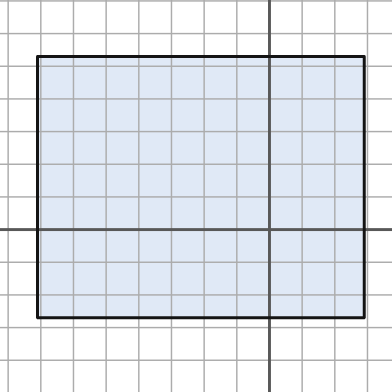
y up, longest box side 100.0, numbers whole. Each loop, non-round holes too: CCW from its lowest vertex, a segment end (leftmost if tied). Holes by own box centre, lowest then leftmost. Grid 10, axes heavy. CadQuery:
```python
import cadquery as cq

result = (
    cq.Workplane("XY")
    .moveTo(-71.0, -27.0)
    .lineTo(29.0, -27.0)
    .lineTo(29.0, 53.0)
    .lineTo(-71.0, 53.0)
    .close()
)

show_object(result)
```